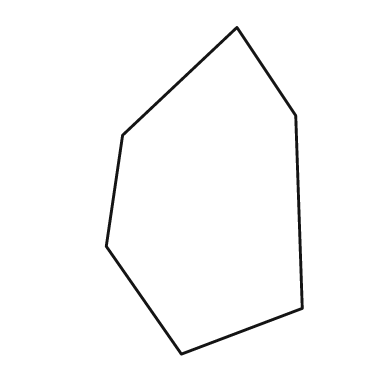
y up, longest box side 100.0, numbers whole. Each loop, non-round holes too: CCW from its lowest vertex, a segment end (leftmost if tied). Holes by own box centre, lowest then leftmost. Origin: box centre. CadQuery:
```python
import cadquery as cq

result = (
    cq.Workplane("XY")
    .moveTo(-7.0, -50.0)
    .lineTo(30.0, -36.0)
    .lineTo(28.0, 23.0)
    .lineTo(10.0, 50.0)
    .lineTo(-25.0, 17.0)
    .lineTo(-30.0, -17.0)
    .close()
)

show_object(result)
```